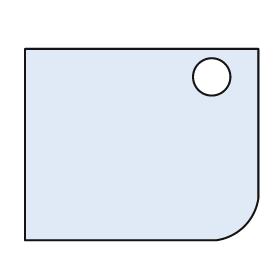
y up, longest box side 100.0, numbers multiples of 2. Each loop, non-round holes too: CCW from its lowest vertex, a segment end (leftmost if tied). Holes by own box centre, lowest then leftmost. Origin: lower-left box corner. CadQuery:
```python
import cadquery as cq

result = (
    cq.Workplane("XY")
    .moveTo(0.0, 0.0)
    .lineTo(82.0, 0.0)
    .threePointArc((94.0, 6.0), (100.0, 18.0))
    .lineTo(100.0, 82.0)
    .lineTo(0.0, 82.0)
    .close()
    .moveTo(80.0, 70.0)
    .circle(8.0)
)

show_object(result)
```